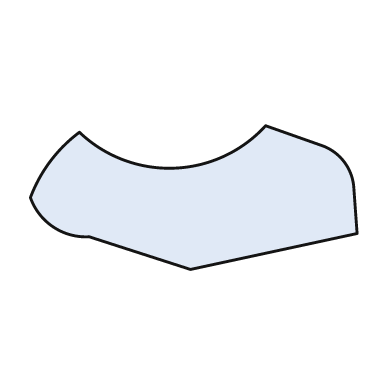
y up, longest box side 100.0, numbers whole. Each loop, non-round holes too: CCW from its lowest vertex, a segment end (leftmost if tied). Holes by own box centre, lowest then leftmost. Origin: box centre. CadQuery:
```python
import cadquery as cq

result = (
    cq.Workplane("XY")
    .moveTo(-1.0, -22.0)
    .lineTo(50.0, -11.0)
    .lineTo(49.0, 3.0)
    .threePointArc((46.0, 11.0), (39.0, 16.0))
    .lineTo(22.0, 22.0)
    .threePointArc((-6.0, 9.0), (-35.0, 20.0))
    .threePointArc((-44.0, 11.0), (-50.0, 0.0))
    .threePointArc((-43.0, -9.0), (-32.0, -12.0))
    .close()
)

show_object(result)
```